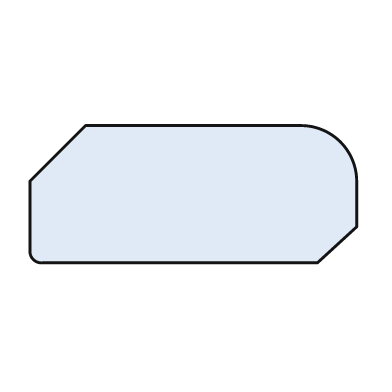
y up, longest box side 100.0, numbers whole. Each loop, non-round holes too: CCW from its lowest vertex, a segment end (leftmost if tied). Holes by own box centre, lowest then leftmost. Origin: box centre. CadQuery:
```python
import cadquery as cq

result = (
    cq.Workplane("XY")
    .moveTo(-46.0, -21.0)
    .lineTo(38.0, -21.0)
    .lineTo(50.0, -10.0)
    .lineTo(50.0, 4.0)
    .threePointArc((45.0, 16.0), (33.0, 21.0))
    .lineTo(-33.0, 21.0)
    .lineTo(-50.0, 4.0)
    .lineTo(-50.0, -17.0)
    .threePointArc((-49.0, -20.0), (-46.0, -21.0))
    .close()
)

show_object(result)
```